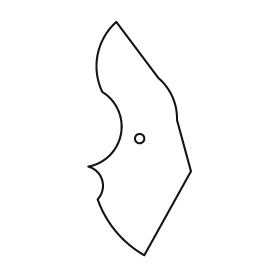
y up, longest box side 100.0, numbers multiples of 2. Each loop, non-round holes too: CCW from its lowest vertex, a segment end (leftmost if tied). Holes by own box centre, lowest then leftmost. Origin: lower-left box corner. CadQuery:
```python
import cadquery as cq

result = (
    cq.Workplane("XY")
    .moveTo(24.0, 0.0)
    .lineTo(44.0, 36.0)
    .lineTo(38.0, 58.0)
    .threePointArc((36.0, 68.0), (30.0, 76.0))
    .lineTo(12.0, 100.0)
    .threePointArc((4.0, 86.0), (6.0, 70.0))
    .threePointArc((14.0, 52.0), (0.0, 38.0))
    .threePointArc((6.0, 32.0), (4.0, 24.0))
    .threePointArc((12.0, 10.0), (24.0, 0.0))
    .close()
    .moveTo(22.0, 50.0)
    .circle(2.0)
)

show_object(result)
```